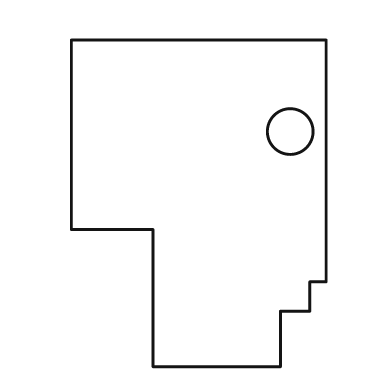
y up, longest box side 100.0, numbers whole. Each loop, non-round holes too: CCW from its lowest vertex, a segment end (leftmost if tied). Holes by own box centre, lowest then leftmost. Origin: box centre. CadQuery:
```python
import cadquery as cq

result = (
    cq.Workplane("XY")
    .moveTo(-14.0, -50.0)
    .lineTo(25.0, -50.0)
    .lineTo(25.0, -33.0)
    .lineTo(34.0, -33.0)
    .lineTo(34.0, -24.0)
    .lineTo(39.0, -24.0)
    .lineTo(39.0, 50.0)
    .lineTo(-39.0, 50.0)
    .lineTo(-39.0, -8.0)
    .lineTo(-14.0, -8.0)
    .close()
    .moveTo(28.0, 22.0)
    .circle(7.0)
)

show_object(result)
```